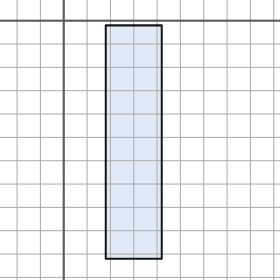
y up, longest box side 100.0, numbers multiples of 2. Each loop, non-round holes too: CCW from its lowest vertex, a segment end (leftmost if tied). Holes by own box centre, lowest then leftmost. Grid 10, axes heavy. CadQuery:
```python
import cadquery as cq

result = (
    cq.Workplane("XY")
    .moveTo(18.0, -102.0)
    .lineTo(42.0, -102.0)
    .lineTo(42.0, -2.0)
    .lineTo(18.0, -2.0)
    .close()
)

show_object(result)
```